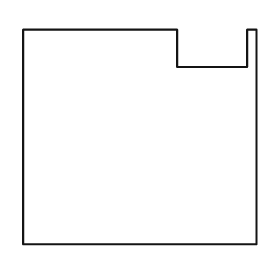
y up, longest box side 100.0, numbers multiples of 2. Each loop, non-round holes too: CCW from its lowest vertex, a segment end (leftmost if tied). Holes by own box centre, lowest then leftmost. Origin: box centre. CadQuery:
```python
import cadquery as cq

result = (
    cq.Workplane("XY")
    .moveTo(-50.0, -46.0)
    .lineTo(50.0, -46.0)
    .lineTo(50.0, 46.0)
    .lineTo(46.0, 46.0)
    .lineTo(46.0, 30.0)
    .lineTo(16.0, 30.0)
    .lineTo(16.0, 46.0)
    .lineTo(-50.0, 46.0)
    .close()
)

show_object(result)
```